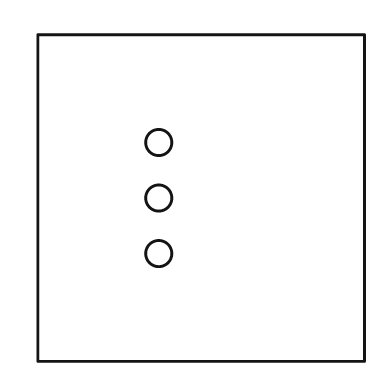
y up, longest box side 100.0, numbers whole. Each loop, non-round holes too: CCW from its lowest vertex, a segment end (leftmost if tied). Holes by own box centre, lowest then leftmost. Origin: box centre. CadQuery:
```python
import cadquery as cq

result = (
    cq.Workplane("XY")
    .moveTo(-50.0, -50.0)
    .lineTo(50.0, -50.0)
    .lineTo(50.0, 50.0)
    .lineTo(-50.0, 50.0)
    .close()
    .moveTo(-13.0, -17.0)
    .circle(4.0)
    .moveTo(-13.0, 0.0)
    .circle(4.0)
    .moveTo(-13.0, 17.0)
    .circle(4.0)
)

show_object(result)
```